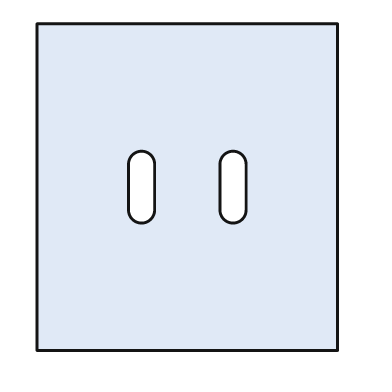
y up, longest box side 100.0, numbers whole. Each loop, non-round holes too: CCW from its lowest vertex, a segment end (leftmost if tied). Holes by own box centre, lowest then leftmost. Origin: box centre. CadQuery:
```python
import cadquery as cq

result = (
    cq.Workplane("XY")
    .moveTo(-46.0, -50.0)
    .lineTo(46.0, -50.0)
    .lineTo(46.0, 50.0)
    .lineTo(-46.0, 50.0)
    .close()
    .moveTo(-18.0, -7.0)
    .threePointArc((-14.0, -11.0), (-10.0, -7.0))
    .lineTo(-10.0, 7.0)
    .threePointArc((-14.0, 11.0), (-18.0, 7.0))
    .close()
    .moveTo(10.0, -7.0)
    .threePointArc((14.0, -11.0), (18.0, -7.0))
    .lineTo(18.0, 7.0)
    .threePointArc((14.0, 11.0), (10.0, 7.0))
    .close()
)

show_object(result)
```